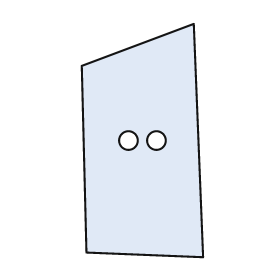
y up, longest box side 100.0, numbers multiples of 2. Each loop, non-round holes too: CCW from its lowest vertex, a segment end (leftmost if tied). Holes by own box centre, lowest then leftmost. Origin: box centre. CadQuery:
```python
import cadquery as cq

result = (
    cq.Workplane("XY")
    .moveTo(26.0, -50.0)
    .lineTo(22.0, 50.0)
    .lineTo(-26.0, 32.0)
    .lineTo(-24.0, -48.0)
    .close()
    .moveTo(-6.0, 0.0)
    .circle(4.0)
    .moveTo(6.0, 0.0)
    .circle(4.0)
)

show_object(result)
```